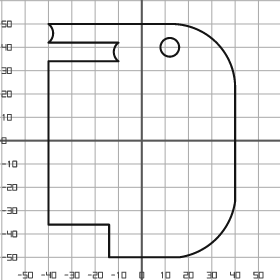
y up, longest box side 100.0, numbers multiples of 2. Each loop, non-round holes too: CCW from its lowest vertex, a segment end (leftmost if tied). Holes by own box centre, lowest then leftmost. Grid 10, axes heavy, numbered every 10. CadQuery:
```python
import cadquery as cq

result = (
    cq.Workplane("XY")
    .moveTo(-14.0, -50.0)
    .lineTo(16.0, -50.0)
    .threePointArc((32.0, -42.0), (40.0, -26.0))
    .lineTo(40.0, 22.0)
    .threePointArc((32.0, 42.0), (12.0, 50.0))
    .lineTo(-40.0, 50.0)
    .threePointArc((-38.0, 46.0), (-40.0, 42.0))
    .lineTo(-10.0, 42.0)
    .threePointArc((-12.0, 38.0), (-10.0, 34.0))
    .lineTo(-40.0, 34.0)
    .lineTo(-40.0, -36.0)
    .lineTo(-14.0, -36.0)
    .close()
    .moveTo(12.0, 40.0)
    .circle(4.0)
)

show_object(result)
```